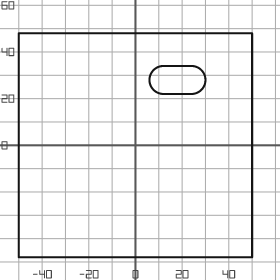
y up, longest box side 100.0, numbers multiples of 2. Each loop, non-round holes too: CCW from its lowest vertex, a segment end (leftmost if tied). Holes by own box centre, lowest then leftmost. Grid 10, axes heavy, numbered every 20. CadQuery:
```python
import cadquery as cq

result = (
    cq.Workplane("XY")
    .moveTo(-50.0, -48.0)
    .lineTo(50.0, -48.0)
    .lineTo(50.0, 48.0)
    .lineTo(-50.0, 48.0)
    .close()
    .moveTo(12.0, 22.0)
    .lineTo(24.0, 22.0)
    .threePointArc((30.0, 28.0), (24.0, 34.0))
    .lineTo(12.0, 34.0)
    .threePointArc((6.0, 28.0), (12.0, 22.0))
    .close()
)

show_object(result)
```